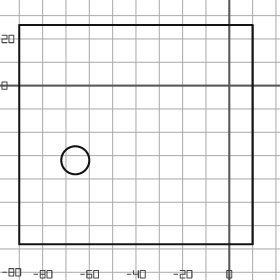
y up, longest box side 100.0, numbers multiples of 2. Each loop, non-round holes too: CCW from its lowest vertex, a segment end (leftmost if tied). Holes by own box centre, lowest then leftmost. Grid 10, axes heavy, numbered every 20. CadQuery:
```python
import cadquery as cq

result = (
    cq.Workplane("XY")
    .moveTo(-90.0, -68.0)
    .lineTo(10.0, -68.0)
    .lineTo(10.0, 26.0)
    .lineTo(-90.0, 26.0)
    .close()
    .moveTo(-66.0, -32.0)
    .circle(6.0)
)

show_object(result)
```